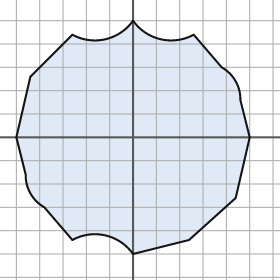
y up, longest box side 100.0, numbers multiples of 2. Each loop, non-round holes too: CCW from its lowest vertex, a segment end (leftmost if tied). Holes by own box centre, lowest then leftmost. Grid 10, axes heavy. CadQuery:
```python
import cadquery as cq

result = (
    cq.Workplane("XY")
    .moveTo(0.0, -50.0)
    .lineTo(24.0, -44.0)
    .lineTo(44.0, -26.0)
    .lineTo(50.0, 0.0)
    .lineTo(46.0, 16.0)
    .threePointArc((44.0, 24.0), (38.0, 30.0))
    .lineTo(26.0, 44.0)
    .threePointArc((12.0, 42.0), (0.0, 50.0))
    .threePointArc((-12.0, 42.0), (-26.0, 44.0))
    .lineTo(-44.0, 26.0)
    .lineTo(-50.0, 0.0)
    .lineTo(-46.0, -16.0)
    .threePointArc((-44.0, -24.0), (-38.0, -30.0))
    .lineTo(-26.0, -44.0)
    .threePointArc((-12.0, -42.0), (0.0, -50.0))
    .close()
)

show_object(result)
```